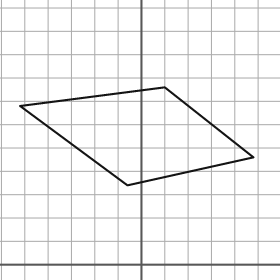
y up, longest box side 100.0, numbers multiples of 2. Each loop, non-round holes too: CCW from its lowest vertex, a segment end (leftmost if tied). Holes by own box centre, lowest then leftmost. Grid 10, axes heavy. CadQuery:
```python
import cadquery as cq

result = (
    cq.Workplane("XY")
    .moveTo(-6.0, 34.0)
    .lineTo(48.0, 46.0)
    .lineTo(10.0, 76.0)
    .lineTo(-52.0, 68.0)
    .close()
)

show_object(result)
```